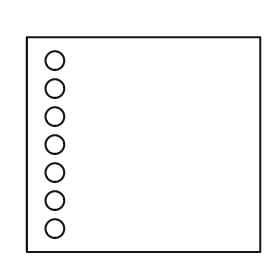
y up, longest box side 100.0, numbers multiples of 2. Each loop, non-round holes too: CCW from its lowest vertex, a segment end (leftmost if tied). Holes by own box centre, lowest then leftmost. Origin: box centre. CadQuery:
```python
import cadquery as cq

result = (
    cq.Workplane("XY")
    .moveTo(-50.0, -46.0)
    .lineTo(50.0, -46.0)
    .lineTo(50.0, 46.0)
    .lineTo(-50.0, 46.0)
    .close()
    .moveTo(-38.0, -36.0)
    .circle(4.0)
    .moveTo(-38.0, -24.0)
    .circle(4.0)
    .moveTo(-38.0, -12.0)
    .circle(4.0)
    .moveTo(-38.0, 0.0)
    .circle(4.0)
    .moveTo(-38.0, 12.0)
    .circle(4.0)
    .moveTo(-38.0, 24.0)
    .circle(4.0)
    .moveTo(-38.0, 36.0)
    .circle(4.0)
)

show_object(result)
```